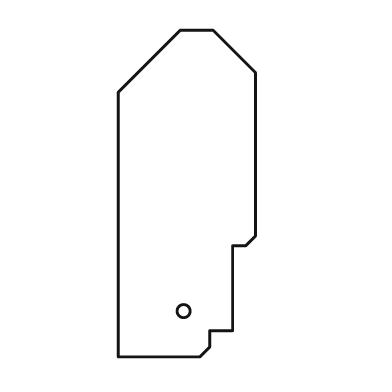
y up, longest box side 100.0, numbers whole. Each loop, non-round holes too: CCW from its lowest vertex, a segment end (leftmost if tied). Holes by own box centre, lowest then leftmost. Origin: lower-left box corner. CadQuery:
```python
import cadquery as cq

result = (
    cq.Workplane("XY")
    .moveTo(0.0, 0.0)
    .lineTo(25.0, 0.0)
    .lineTo(28.0, 3.0)
    .lineTo(28.0, 8.0)
    .lineTo(35.0, 8.0)
    .lineTo(35.0, 34.0)
    .lineTo(39.0, 34.0)
    .lineTo(42.0, 37.0)
    .lineTo(42.0, 87.0)
    .lineTo(29.0, 100.0)
    .lineTo(19.0, 100.0)
    .lineTo(0.0, 81.0)
    .close()
    .moveTo(20.0, 14.0)
    .circle(2.0)
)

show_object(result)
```